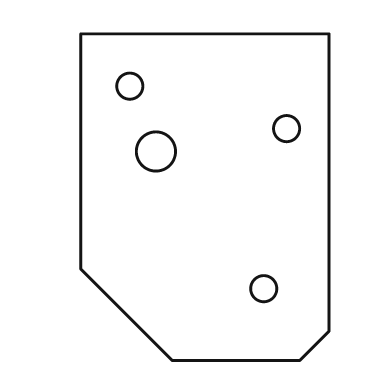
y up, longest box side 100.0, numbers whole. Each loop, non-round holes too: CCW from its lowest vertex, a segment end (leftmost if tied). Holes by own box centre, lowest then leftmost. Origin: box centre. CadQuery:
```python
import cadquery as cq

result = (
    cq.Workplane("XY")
    .moveTo(-10.0, -50.0)
    .lineTo(29.0, -50.0)
    .lineTo(38.0, -41.0)
    .lineTo(38.0, 50.0)
    .lineTo(-38.0, 50.0)
    .lineTo(-38.0, -22.0)
    .close()
    .moveTo(18.0, -28.0)
    .circle(4.0)
    .moveTo(-15.0, 14.0)
    .circle(6.0)
    .moveTo(25.0, 21.0)
    .circle(4.0)
    .moveTo(-23.0, 34.0)
    .circle(4.0)
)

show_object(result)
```